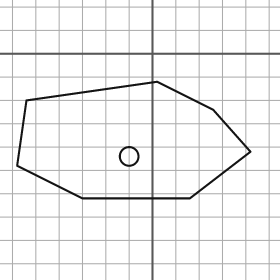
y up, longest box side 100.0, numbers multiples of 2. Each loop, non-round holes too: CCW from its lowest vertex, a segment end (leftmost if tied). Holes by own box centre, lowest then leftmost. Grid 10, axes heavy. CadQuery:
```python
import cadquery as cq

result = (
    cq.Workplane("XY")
    .moveTo(-30.0, -62.0)
    .lineTo(16.0, -62.0)
    .lineTo(42.0, -42.0)
    .lineTo(26.0, -24.0)
    .lineTo(2.0, -12.0)
    .lineTo(-54.0, -20.0)
    .lineTo(-58.0, -48.0)
    .close()
    .moveTo(-10.0, -44.0)
    .circle(4.0)
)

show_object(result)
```